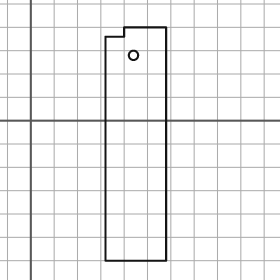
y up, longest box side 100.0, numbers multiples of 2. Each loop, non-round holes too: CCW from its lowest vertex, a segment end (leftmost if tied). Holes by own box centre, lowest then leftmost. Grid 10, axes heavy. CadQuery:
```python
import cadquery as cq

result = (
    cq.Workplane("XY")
    .moveTo(32.0, -60.0)
    .lineTo(58.0, -60.0)
    .lineTo(58.0, 40.0)
    .lineTo(40.0, 40.0)
    .lineTo(40.0, 36.0)
    .lineTo(32.0, 36.0)
    .close()
    .moveTo(44.0, 28.0)
    .circle(2.0)
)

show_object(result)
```